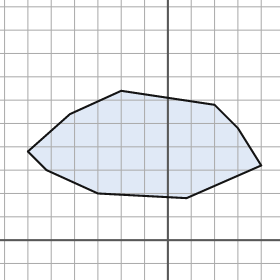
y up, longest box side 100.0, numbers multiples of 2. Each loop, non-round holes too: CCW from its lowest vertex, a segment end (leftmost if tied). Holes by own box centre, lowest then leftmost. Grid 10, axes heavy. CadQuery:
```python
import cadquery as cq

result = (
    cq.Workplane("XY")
    .moveTo(8.0, 18.0)
    .lineTo(40.0, 32.0)
    .lineTo(30.0, 48.0)
    .lineTo(20.0, 58.0)
    .lineTo(-20.0, 64.0)
    .lineTo(-42.0, 54.0)
    .lineTo(-60.0, 38.0)
    .lineTo(-52.0, 30.0)
    .lineTo(-30.0, 20.0)
    .close()
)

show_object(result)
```